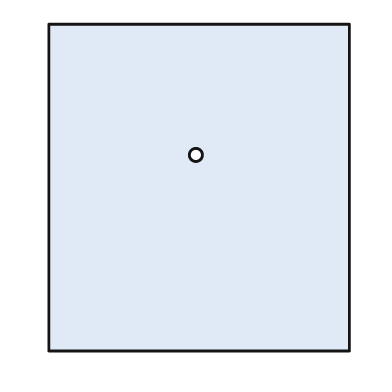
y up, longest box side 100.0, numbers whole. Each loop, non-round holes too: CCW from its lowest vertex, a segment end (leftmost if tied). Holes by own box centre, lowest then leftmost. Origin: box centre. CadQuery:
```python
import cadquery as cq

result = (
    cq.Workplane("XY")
    .moveTo(-46.0, -50.0)
    .lineTo(46.0, -50.0)
    .lineTo(46.0, 50.0)
    .lineTo(-46.0, 50.0)
    .close()
    .moveTo(-1.0, 10.0)
    .circle(2.0)
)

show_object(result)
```